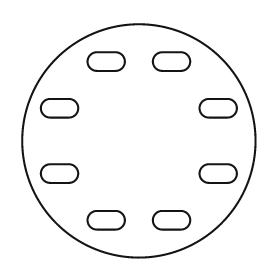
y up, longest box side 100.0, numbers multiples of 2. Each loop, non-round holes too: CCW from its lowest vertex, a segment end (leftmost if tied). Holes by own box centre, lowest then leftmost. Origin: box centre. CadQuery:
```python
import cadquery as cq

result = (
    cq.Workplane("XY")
    .moveTo(0.0, 0.0)
    .circle(50.0)
    .moveTo(-18.0, -38.0)
    .lineTo(-10.0, -38.0)
    .threePointArc((-6.0, -34.0), (-10.0, -30.0))
    .lineTo(-18.0, -30.0)
    .threePointArc((-22.0, -34.0), (-18.0, -38.0))
    .close()
    .moveTo(10.0, -38.0)
    .lineTo(18.0, -38.0)
    .threePointArc((22.0, -34.0), (18.0, -30.0))
    .lineTo(10.0, -30.0)
    .threePointArc((6.0, -34.0), (10.0, -38.0))
    .close()
    .moveTo(-38.0, -18.0)
    .lineTo(-30.0, -18.0)
    .threePointArc((-26.0, -14.0), (-30.0, -10.0))
    .lineTo(-38.0, -10.0)
    .threePointArc((-42.0, -14.0), (-38.0, -18.0))
    .close()
    .moveTo(30.0, -18.0)
    .lineTo(38.0, -18.0)
    .threePointArc((42.0, -14.0), (38.0, -10.0))
    .lineTo(30.0, -10.0)
    .threePointArc((26.0, -14.0), (30.0, -18.0))
    .close()
    .moveTo(-38.0, 10.0)
    .lineTo(-30.0, 10.0)
    .threePointArc((-26.0, 14.0), (-30.0, 18.0))
    .lineTo(-38.0, 18.0)
    .threePointArc((-42.0, 14.0), (-38.0, 10.0))
    .close()
    .moveTo(30.0, 10.0)
    .lineTo(38.0, 10.0)
    .threePointArc((42.0, 14.0), (38.0, 18.0))
    .lineTo(30.0, 18.0)
    .threePointArc((26.0, 14.0), (30.0, 10.0))
    .close()
    .moveTo(-18.0, 30.0)
    .lineTo(-10.0, 30.0)
    .threePointArc((-6.0, 34.0), (-10.0, 38.0))
    .lineTo(-18.0, 38.0)
    .threePointArc((-22.0, 34.0), (-18.0, 30.0))
    .close()
    .moveTo(10.0, 30.0)
    .lineTo(18.0, 30.0)
    .threePointArc((22.0, 34.0), (18.0, 38.0))
    .lineTo(10.0, 38.0)
    .threePointArc((6.0, 34.0), (10.0, 30.0))
    .close()
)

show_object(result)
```